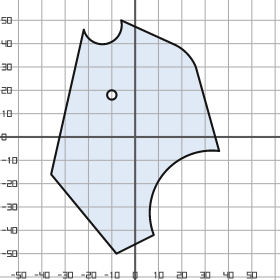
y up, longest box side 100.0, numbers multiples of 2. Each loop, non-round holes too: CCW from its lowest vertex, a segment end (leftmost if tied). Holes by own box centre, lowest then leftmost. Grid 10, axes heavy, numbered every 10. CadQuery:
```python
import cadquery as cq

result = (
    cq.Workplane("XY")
    .moveTo(-8.0, -50.0)
    .lineTo(8.0, -42.0)
    .threePointArc((12.0, -16.0), (36.0, -6.0))
    .lineTo(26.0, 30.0)
    .threePointArc((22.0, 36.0), (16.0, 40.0))
    .lineTo(-6.0, 50.0)
    .threePointArc((-12.0, 40.0), (-22.0, 46.0))
    .lineTo(-36.0, -16.0)
    .close()
    .moveTo(-10.0, 18.0)
    .circle(2.0)
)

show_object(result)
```